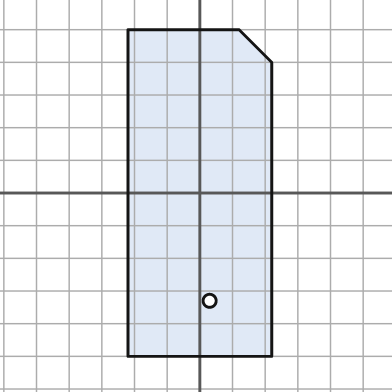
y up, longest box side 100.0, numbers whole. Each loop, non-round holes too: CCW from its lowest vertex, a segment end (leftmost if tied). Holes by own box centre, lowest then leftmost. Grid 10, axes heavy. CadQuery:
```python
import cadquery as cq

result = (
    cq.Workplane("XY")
    .moveTo(-22.0, -50.0)
    .lineTo(22.0, -50.0)
    .lineTo(22.0, 40.0)
    .lineTo(12.0, 50.0)
    .lineTo(-22.0, 50.0)
    .close()
    .moveTo(3.0, -33.0)
    .circle(2.0)
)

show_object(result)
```